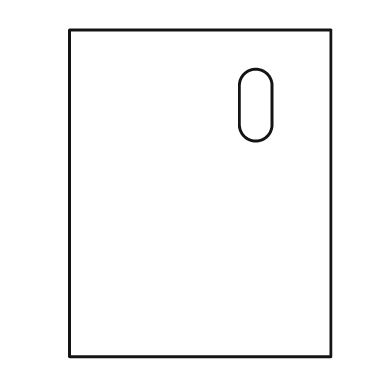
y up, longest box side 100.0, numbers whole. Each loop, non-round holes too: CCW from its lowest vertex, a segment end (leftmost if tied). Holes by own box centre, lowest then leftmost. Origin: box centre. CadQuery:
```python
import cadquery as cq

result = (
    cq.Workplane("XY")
    .moveTo(-40.0, -50.0)
    .lineTo(40.0, -50.0)
    .lineTo(40.0, 50.0)
    .lineTo(-40.0, 50.0)
    .close()
    .moveTo(12.0, 21.0)
    .threePointArc((17.0, 16.0), (22.0, 21.0))
    .lineTo(22.0, 33.0)
    .threePointArc((17.0, 38.0), (12.0, 33.0))
    .close()
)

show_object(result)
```